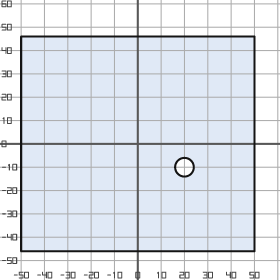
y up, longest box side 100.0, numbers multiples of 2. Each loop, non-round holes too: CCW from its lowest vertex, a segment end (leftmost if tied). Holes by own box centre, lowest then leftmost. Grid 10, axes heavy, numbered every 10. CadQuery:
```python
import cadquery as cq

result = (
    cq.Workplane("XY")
    .moveTo(-50.0, -46.0)
    .lineTo(50.0, -46.0)
    .lineTo(50.0, 46.0)
    .lineTo(-50.0, 46.0)
    .close()
    .moveTo(20.0, -10.0)
    .circle(4.0)
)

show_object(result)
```